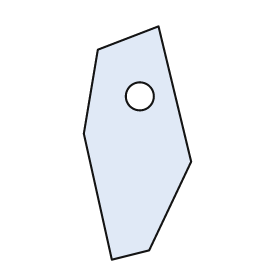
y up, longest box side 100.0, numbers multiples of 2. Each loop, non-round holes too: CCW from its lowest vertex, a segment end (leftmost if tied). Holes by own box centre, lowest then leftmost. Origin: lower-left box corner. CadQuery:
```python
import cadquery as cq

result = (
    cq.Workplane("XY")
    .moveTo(12.0, 0.0)
    .lineTo(28.0, 4.0)
    .lineTo(46.0, 42.0)
    .lineTo(32.0, 100.0)
    .lineTo(6.0, 90.0)
    .lineTo(0.0, 54.0)
    .close()
    .moveTo(24.0, 70.0)
    .circle(6.0)
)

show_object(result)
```